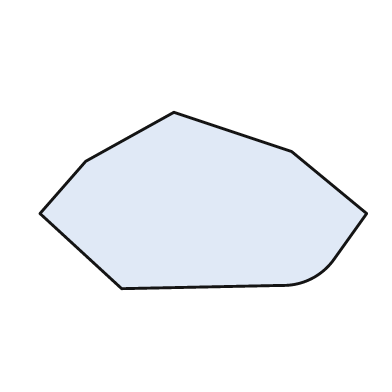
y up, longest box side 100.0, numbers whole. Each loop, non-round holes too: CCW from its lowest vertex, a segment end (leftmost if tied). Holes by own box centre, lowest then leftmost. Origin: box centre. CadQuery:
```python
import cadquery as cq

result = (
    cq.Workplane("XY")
    .moveTo(-25.0, -27.0)
    .lineTo(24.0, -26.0)
    .threePointArc((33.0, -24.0), (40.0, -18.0))
    .lineTo(50.0, -4.0)
    .lineTo(27.0, 15.0)
    .lineTo(-9.0, 27.0)
    .lineTo(-36.0, 12.0)
    .lineTo(-50.0, -4.0)
    .close()
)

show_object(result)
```